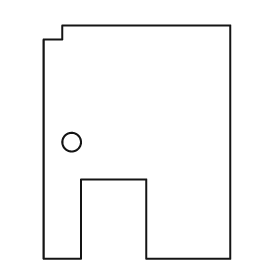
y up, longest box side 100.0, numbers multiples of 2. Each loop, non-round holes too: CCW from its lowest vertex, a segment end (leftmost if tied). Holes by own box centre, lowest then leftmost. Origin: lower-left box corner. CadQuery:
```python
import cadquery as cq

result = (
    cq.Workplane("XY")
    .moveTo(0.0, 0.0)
    .lineTo(16.0, 0.0)
    .lineTo(16.0, 34.0)
    .lineTo(44.0, 34.0)
    .lineTo(44.0, 0.0)
    .lineTo(80.0, 0.0)
    .lineTo(80.0, 100.0)
    .lineTo(8.0, 100.0)
    .lineTo(8.0, 94.0)
    .lineTo(0.0, 94.0)
    .close()
    .moveTo(12.0, 50.0)
    .circle(4.0)
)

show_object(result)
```